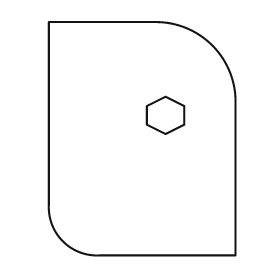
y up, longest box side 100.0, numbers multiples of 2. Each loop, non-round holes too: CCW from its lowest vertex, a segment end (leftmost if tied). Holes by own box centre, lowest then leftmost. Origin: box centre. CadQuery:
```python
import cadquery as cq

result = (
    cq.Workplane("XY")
    .moveTo(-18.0, -50.0)
    .lineTo(40.0, -50.0)
    .lineTo(40.0, 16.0)
    .threePointArc((30.0, 40.0), (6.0, 50.0))
    .lineTo(-40.0, 50.0)
    .lineTo(-40.0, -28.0)
    .threePointArc((-34.0, -44.0), (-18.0, -50.0))
    .close()
    .moveTo(10.0, 2.0)
    .lineTo(18.0, 6.0)
    .lineTo(18.0, 14.0)
    .lineTo(10.0, 18.0)
    .lineTo(2.0, 14.0)
    .lineTo(2.0, 6.0)
    .close()
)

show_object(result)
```